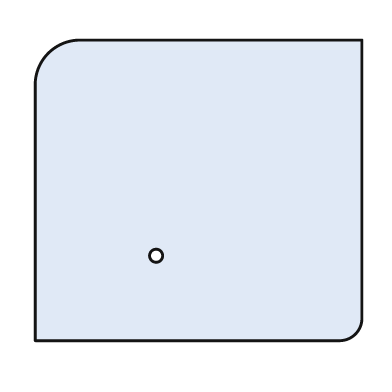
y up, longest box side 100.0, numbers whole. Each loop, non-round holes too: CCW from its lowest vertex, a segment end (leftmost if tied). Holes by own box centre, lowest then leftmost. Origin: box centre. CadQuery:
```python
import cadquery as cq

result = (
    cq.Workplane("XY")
    .moveTo(-50.0, -46.0)
    .lineTo(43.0, -46.0)
    .threePointArc((48.0, -44.0), (50.0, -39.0))
    .lineTo(50.0, 46.0)
    .lineTo(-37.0, 46.0)
    .threePointArc((-46.0, 42.0), (-50.0, 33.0))
    .close()
    .moveTo(-13.0, -20.0)
    .circle(2.0)
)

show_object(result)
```